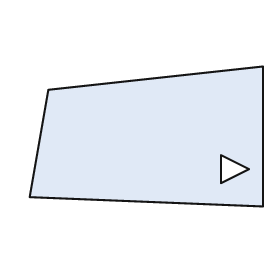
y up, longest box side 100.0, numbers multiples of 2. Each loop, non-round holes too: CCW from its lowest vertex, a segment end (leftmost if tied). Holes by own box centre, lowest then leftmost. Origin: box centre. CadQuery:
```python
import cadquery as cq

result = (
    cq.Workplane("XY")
    .moveTo(50.0, -30.0)
    .lineTo(50.0, 30.0)
    .lineTo(-42.0, 20.0)
    .lineTo(-50.0, -26.0)
    .close()
    .moveTo(32.0, -20.0)
    .lineTo(44.0, -14.0)
    .lineTo(32.0, -8.0)
    .close()
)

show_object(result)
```